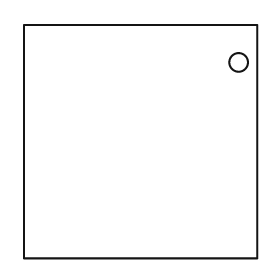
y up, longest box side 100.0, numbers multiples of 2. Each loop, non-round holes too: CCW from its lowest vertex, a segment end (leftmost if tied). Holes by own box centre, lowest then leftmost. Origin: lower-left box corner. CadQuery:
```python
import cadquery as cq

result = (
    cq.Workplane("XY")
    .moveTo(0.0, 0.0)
    .lineTo(100.0, 0.0)
    .lineTo(100.0, 100.0)
    .lineTo(0.0, 100.0)
    .close()
    .moveTo(92.0, 84.0)
    .circle(4.0)
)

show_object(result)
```